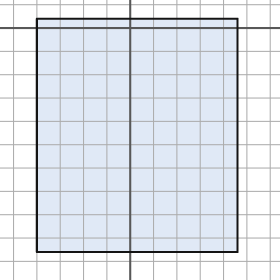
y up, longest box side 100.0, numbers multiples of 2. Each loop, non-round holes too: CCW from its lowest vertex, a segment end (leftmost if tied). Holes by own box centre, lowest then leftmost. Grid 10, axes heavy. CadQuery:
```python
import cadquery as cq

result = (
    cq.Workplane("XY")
    .moveTo(-40.0, -96.0)
    .lineTo(46.0, -96.0)
    .lineTo(46.0, 4.0)
    .lineTo(-40.0, 4.0)
    .close()
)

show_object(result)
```